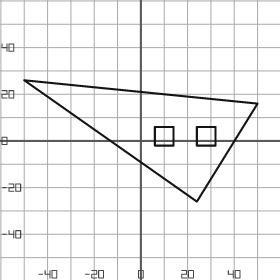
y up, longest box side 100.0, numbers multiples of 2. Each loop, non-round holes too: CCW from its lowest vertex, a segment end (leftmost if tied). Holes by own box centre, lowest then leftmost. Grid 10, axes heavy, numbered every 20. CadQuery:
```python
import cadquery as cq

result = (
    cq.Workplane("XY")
    .moveTo(24.0, -26.0)
    .lineTo(50.0, 16.0)
    .lineTo(-50.0, 26.0)
    .close()
    .moveTo(6.0, -2.0)
    .lineTo(14.0, -2.0)
    .lineTo(14.0, 6.0)
    .lineTo(6.0, 6.0)
    .close()
    .moveTo(24.0, -2.0)
    .lineTo(32.0, -2.0)
    .lineTo(32.0, 6.0)
    .lineTo(24.0, 6.0)
    .close()
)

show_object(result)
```